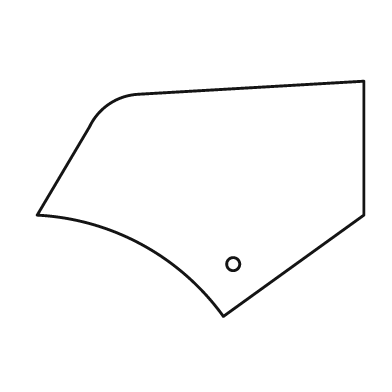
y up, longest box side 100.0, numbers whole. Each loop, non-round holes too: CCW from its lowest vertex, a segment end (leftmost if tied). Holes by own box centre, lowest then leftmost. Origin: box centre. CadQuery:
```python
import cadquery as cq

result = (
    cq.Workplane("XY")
    .moveTo(7.0, -36.0)
    .lineTo(50.0, -5.0)
    .lineTo(50.0, 36.0)
    .lineTo(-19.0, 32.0)
    .threePointArc((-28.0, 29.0), (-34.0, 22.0))
    .lineTo(-50.0, -5.0)
    .threePointArc((-18.0, -14.0), (7.0, -36.0))
    .close()
    .moveTo(10.0, -20.0)
    .circle(2.0)
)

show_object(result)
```